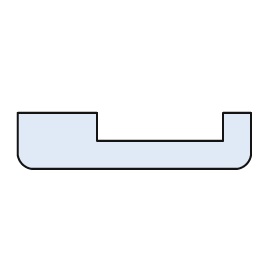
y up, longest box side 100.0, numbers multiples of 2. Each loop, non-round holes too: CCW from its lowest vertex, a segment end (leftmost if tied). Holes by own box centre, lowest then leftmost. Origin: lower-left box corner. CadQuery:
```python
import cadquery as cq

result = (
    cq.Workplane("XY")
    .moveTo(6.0, 0.0)
    .lineTo(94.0, 0.0)
    .threePointArc((98.0, 2.0), (100.0, 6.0))
    .lineTo(100.0, 24.0)
    .lineTo(88.0, 24.0)
    .lineTo(88.0, 12.0)
    .lineTo(34.0, 12.0)
    .lineTo(34.0, 24.0)
    .lineTo(0.0, 24.0)
    .lineTo(0.0, 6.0)
    .threePointArc((2.0, 2.0), (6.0, 0.0))
    .close()
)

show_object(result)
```